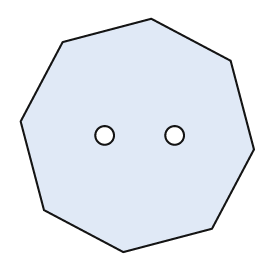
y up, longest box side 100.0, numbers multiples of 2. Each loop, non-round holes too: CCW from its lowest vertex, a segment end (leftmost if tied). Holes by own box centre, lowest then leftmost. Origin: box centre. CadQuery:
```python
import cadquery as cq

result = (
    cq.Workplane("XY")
    .moveTo(-6.0, -50.0)
    .lineTo(32.0, -40.0)
    .lineTo(50.0, -6.0)
    .lineTo(40.0, 32.0)
    .lineTo(6.0, 50.0)
    .lineTo(-32.0, 40.0)
    .lineTo(-50.0, 6.0)
    .lineTo(-40.0, -32.0)
    .close()
    .moveTo(-14.0, 0.0)
    .circle(4.0)
    .moveTo(16.0, 0.0)
    .circle(4.0)
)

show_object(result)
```